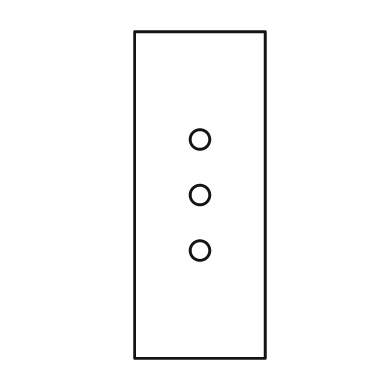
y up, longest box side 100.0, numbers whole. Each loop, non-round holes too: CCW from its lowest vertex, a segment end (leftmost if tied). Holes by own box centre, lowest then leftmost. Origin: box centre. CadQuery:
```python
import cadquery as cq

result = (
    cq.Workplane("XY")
    .moveTo(-20.0, -50.0)
    .lineTo(20.0, -50.0)
    .lineTo(20.0, 50.0)
    .lineTo(-20.0, 50.0)
    .close()
    .moveTo(0.0, -17.0)
    .circle(3.0)
    .moveTo(0.0, 0.0)
    .circle(3.0)
    .moveTo(0.0, 17.0)
    .circle(3.0)
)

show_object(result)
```